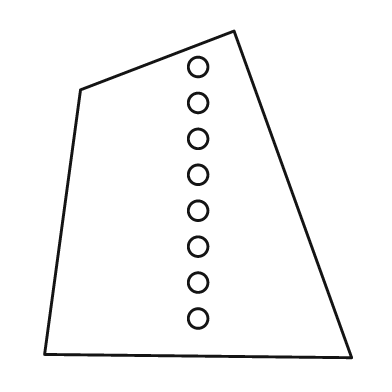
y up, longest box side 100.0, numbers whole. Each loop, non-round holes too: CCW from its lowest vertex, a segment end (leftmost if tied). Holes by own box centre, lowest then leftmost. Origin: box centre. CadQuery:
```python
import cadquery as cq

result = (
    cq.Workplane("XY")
    .moveTo(47.0, -50.0)
    .lineTo(11.0, 50.0)
    .lineTo(-36.0, 32.0)
    .lineTo(-47.0, -49.0)
    .close()
    .moveTo(0.0, -38.0)
    .circle(3.0)
    .moveTo(0.0, -27.0)
    .circle(3.0)
    .moveTo(0.0, -16.0)
    .circle(3.0)
    .moveTo(0.0, -5.0)
    .circle(3.0)
    .moveTo(0.0, 6.0)
    .circle(3.0)
    .moveTo(0.0, 17.0)
    .circle(3.0)
    .moveTo(0.0, 28.0)
    .circle(3.0)
    .moveTo(0.0, 39.0)
    .circle(3.0)
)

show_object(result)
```